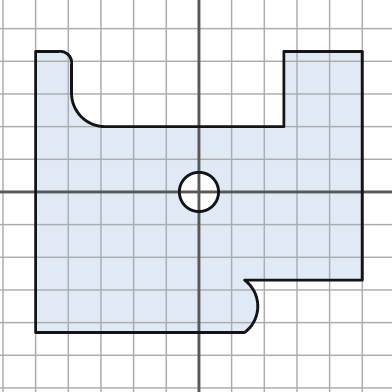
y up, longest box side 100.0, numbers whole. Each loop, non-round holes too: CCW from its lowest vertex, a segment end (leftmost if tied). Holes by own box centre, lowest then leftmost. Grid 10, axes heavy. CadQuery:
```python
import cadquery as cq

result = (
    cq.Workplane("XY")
    .moveTo(-50.0, -43.0)
    .lineTo(14.0, -43.0)
    .threePointArc((18.0, -35.0), (14.0, -27.0))
    .lineTo(50.0, -27.0)
    .lineTo(50.0, 43.0)
    .lineTo(26.0, 43.0)
    .lineTo(26.0, 20.0)
    .lineTo(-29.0, 20.0)
    .threePointArc((-36.0, 23.0), (-39.0, 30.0))
    .lineTo(-39.0, 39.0)
    .threePointArc((-40.0, 42.0), (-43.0, 43.0))
    .lineTo(-50.0, 43.0)
    .close()
    .moveTo(0.0, 0.0)
    .circle(6.0)
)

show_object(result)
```